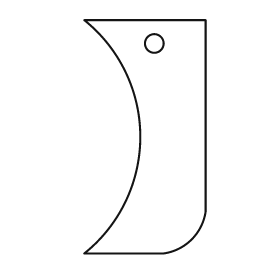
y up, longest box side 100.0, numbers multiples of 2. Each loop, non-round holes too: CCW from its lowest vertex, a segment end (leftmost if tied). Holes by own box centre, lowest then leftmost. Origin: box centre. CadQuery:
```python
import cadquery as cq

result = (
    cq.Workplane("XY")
    .moveTo(-26.0, -50.0)
    .lineTo(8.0, -50.0)
    .threePointArc((20.0, -44.0), (26.0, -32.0))
    .lineTo(26.0, 50.0)
    .lineTo(-26.0, 50.0)
    .threePointArc((-2.0, 0.0), (-26.0, -50.0))
    .close()
    .moveTo(4.0, 40.0)
    .circle(4.0)
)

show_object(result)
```